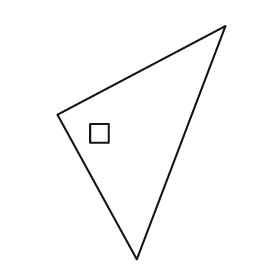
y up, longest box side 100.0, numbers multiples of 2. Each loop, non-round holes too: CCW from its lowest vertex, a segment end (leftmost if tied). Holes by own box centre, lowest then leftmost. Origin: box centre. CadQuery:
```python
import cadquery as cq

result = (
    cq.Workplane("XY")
    .moveTo(-2.0, -50.0)
    .lineTo(36.0, 50.0)
    .lineTo(-36.0, 12.0)
    .close()
    .moveTo(-22.0, 0.0)
    .lineTo(-14.0, 0.0)
    .lineTo(-14.0, 8.0)
    .lineTo(-22.0, 8.0)
    .close()
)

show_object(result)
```